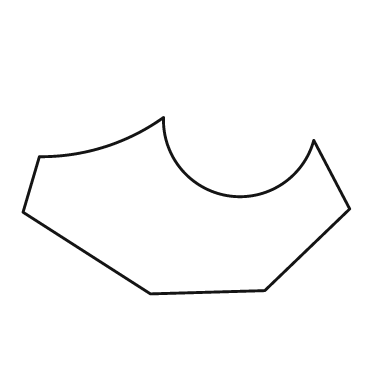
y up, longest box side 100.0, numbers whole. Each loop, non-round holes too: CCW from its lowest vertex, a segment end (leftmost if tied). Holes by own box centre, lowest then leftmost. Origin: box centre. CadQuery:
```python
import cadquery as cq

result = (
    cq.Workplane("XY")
    .moveTo(-11.0, -27.0)
    .lineTo(24.0, -26.0)
    .lineTo(50.0, -1.0)
    .lineTo(39.0, 20.0)
    .threePointArc((13.0, 3.0), (-7.0, 27.0))
    .threePointArc((-25.0, 18.0), (-45.0, 15.0))
    .lineTo(-50.0, -2.0)
    .close()
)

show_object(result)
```